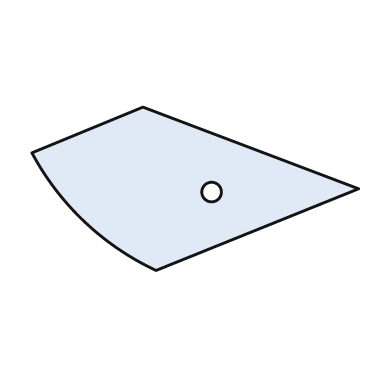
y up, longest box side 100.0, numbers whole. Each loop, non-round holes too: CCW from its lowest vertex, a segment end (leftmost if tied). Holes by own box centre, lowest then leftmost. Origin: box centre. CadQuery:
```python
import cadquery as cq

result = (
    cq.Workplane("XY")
    .moveTo(-12.0, -25.0)
    .lineTo(50.0, 0.0)
    .lineTo(-16.0, 25.0)
    .lineTo(-50.0, 11.0)
    .threePointArc((-34.0, -10.0), (-12.0, -25.0))
    .close()
    .moveTo(5.0, -1.0)
    .circle(3.0)
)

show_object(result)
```